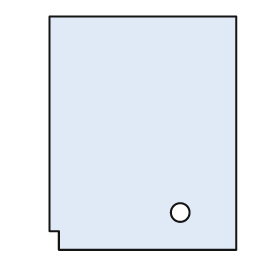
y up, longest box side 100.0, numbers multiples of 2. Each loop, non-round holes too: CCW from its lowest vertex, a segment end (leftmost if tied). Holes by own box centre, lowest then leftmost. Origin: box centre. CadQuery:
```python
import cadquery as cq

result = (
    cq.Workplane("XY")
    .moveTo(-36.0, -50.0)
    .lineTo(40.0, -50.0)
    .lineTo(40.0, 50.0)
    .lineTo(-40.0, 50.0)
    .lineTo(-40.0, -42.0)
    .lineTo(-36.0, -42.0)
    .close()
    .moveTo(16.0, -34.0)
    .circle(4.0)
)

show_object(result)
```